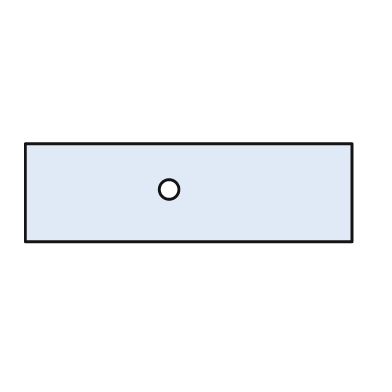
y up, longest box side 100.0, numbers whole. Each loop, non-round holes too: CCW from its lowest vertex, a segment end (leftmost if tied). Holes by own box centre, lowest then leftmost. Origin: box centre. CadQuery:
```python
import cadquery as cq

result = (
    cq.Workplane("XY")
    .moveTo(-50.0, -15.0)
    .lineTo(50.0, -15.0)
    .lineTo(50.0, 15.0)
    .lineTo(-50.0, 15.0)
    .close()
    .moveTo(-6.0, 1.0)
    .circle(3.0)
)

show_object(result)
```